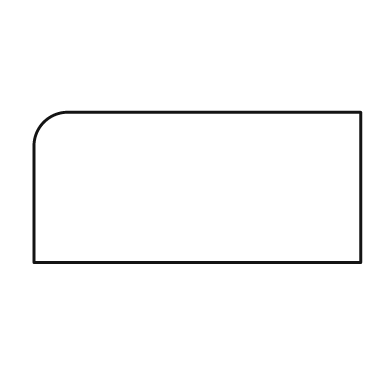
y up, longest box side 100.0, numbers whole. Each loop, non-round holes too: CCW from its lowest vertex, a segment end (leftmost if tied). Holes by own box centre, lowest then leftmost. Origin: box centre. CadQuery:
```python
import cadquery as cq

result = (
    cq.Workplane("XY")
    .moveTo(-50.0, -23.0)
    .lineTo(50.0, -23.0)
    .lineTo(50.0, 23.0)
    .lineTo(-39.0, 23.0)
    .threePointArc((-47.0, 20.0), (-50.0, 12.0))
    .close()
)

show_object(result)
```